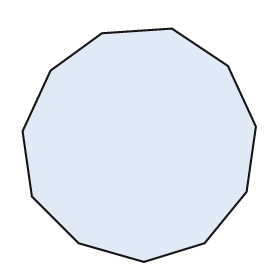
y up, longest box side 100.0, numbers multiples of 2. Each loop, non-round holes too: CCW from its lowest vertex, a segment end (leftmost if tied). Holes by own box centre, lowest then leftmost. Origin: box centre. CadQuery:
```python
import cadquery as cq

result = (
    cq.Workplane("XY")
    .moveTo(2.0, -50.0)
    .lineTo(28.0, -42.0)
    .lineTo(46.0, -20.0)
    .lineTo(50.0, 8.0)
    .lineTo(38.0, 34.0)
    .lineTo(14.0, 50.0)
    .lineTo(-16.0, 48.0)
    .lineTo(-38.0, 32.0)
    .lineTo(-50.0, 6.0)
    .lineTo(-46.0, -22.0)
    .lineTo(-26.0, -42.0)
    .close()
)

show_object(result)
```